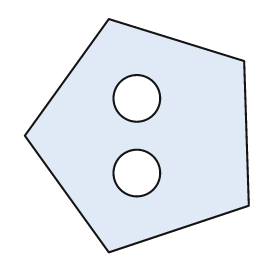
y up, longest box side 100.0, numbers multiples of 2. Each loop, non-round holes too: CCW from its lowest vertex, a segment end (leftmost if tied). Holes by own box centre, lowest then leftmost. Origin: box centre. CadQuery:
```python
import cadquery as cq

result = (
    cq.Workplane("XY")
    .moveTo(-12.0, -50.0)
    .lineTo(48.0, -30.0)
    .lineTo(46.0, 32.0)
    .lineTo(-12.0, 50.0)
    .lineTo(-48.0, 0.0)
    .close()
    .moveTo(0.0, -16.0)
    .circle(10.0)
    .moveTo(0.0, 16.0)
    .circle(10.0)
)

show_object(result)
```